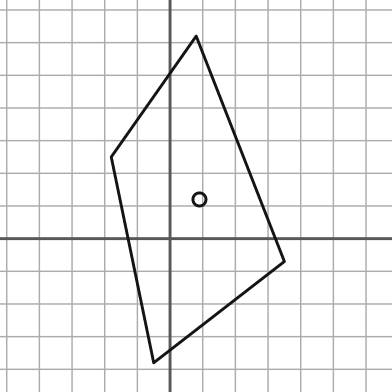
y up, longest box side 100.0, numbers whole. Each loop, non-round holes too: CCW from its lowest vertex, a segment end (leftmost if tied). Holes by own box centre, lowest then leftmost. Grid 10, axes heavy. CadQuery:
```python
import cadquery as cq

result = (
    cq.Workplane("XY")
    .moveTo(-5.0, -38.0)
    .lineTo(35.0, -7.0)
    .lineTo(8.0, 62.0)
    .lineTo(-18.0, 25.0)
    .close()
    .moveTo(9.0, 12.0)
    .circle(2.0)
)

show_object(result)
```